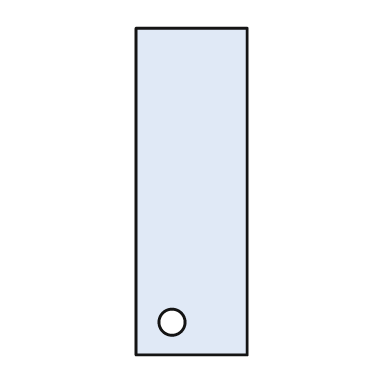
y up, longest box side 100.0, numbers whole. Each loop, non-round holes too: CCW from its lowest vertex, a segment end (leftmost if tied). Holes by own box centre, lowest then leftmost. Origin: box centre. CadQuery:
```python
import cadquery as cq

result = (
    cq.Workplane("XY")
    .moveTo(-17.0, -50.0)
    .lineTo(17.0, -50.0)
    .lineTo(17.0, 50.0)
    .lineTo(-17.0, 50.0)
    .close()
    .moveTo(-6.0, -40.0)
    .circle(4.0)
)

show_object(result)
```